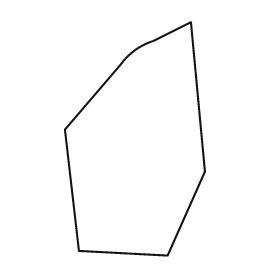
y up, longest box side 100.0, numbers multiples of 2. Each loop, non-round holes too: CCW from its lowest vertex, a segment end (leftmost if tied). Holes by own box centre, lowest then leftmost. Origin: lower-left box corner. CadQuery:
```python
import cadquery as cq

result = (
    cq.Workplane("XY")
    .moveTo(44.0, 0.0)
    .lineTo(60.0, 36.0)
    .lineTo(54.0, 100.0)
    .lineTo(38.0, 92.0)
    .threePointArc((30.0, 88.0), (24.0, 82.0))
    .lineTo(0.0, 54.0)
    .lineTo(6.0, 2.0)
    .close()
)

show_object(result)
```